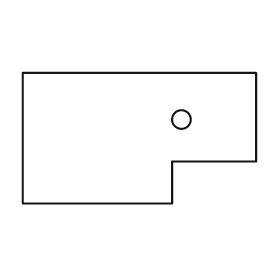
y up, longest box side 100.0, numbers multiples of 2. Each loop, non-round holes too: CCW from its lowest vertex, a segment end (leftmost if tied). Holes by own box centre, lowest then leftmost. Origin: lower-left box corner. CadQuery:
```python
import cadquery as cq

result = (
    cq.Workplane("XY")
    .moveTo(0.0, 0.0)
    .lineTo(64.0, 0.0)
    .lineTo(64.0, 18.0)
    .lineTo(100.0, 18.0)
    .lineTo(100.0, 56.0)
    .lineTo(0.0, 56.0)
    .close()
    .moveTo(68.0, 36.0)
    .circle(4.0)
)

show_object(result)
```